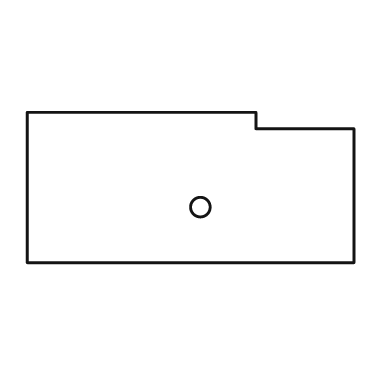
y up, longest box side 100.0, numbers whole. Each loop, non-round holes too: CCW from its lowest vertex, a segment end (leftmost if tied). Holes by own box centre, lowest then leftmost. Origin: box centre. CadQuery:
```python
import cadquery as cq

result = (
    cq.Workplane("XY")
    .moveTo(-50.0, -23.0)
    .lineTo(50.0, -23.0)
    .lineTo(50.0, 18.0)
    .lineTo(20.0, 18.0)
    .lineTo(20.0, 23.0)
    .lineTo(-50.0, 23.0)
    .close()
    .moveTo(3.0, -6.0)
    .circle(3.0)
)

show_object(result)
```